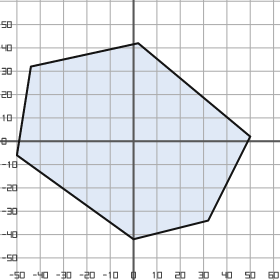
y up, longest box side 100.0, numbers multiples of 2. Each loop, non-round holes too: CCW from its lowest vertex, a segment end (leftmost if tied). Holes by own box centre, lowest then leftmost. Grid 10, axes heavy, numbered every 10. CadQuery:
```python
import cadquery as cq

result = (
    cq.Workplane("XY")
    .moveTo(0.0, -42.0)
    .lineTo(32.0, -34.0)
    .lineTo(50.0, 2.0)
    .lineTo(2.0, 42.0)
    .lineTo(-44.0, 32.0)
    .lineTo(-50.0, -6.0)
    .close()
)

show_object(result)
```